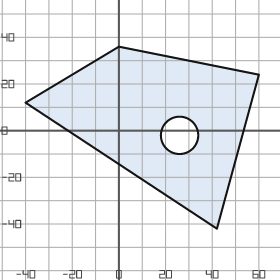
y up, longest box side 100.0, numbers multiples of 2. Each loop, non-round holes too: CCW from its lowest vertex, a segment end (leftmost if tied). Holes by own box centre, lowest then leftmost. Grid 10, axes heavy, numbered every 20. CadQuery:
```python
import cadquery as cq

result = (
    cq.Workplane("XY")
    .moveTo(42.0, -42.0)
    .lineTo(60.0, 24.0)
    .lineTo(0.0, 36.0)
    .lineTo(-40.0, 12.0)
    .close()
    .moveTo(26.0, -2.0)
    .circle(8.0)
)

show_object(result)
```